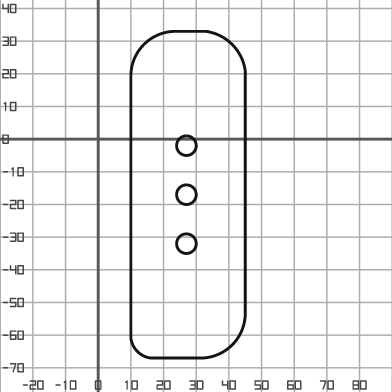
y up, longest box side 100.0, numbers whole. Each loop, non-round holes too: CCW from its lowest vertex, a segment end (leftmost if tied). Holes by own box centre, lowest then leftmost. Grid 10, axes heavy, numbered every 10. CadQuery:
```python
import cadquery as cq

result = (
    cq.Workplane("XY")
    .moveTo(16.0, -67.0)
    .lineTo(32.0, -67.0)
    .threePointArc((41.0, -63.0), (45.0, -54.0))
    .lineTo(45.0, 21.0)
    .threePointArc((41.0, 29.0), (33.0, 33.0))
    .lineTo(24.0, 33.0)
    .threePointArc((14.0, 29.0), (10.0, 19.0))
    .lineTo(10.0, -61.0)
    .threePointArc((12.0, -65.0), (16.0, -67.0))
    .close()
    .moveTo(27.0, -32.0)
    .circle(3.0)
    .moveTo(27.0, -17.0)
    .circle(3.0)
    .moveTo(27.0, -2.0)
    .circle(3.0)
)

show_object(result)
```